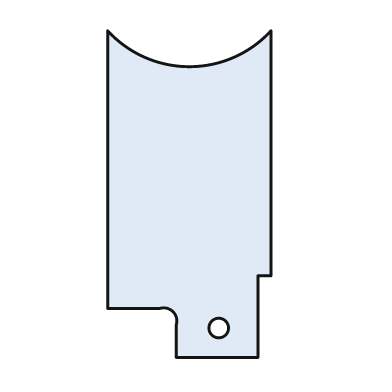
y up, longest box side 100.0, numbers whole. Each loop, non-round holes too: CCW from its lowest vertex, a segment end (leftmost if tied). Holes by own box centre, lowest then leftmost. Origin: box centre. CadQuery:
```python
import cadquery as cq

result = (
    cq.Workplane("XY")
    .moveTo(-4.0, -50.0)
    .lineTo(21.0, -50.0)
    .lineTo(21.0, -25.0)
    .lineTo(25.0, -25.0)
    .lineTo(25.0, 50.0)
    .threePointArc((0.0, 39.0), (-25.0, 50.0))
    .lineTo(-25.0, -35.0)
    .lineTo(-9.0, -35.0)
    .threePointArc((-5.0, -36.0), (-4.0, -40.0))
    .close()
    .moveTo(9.0, -41.0)
    .circle(3.0)
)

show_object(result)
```